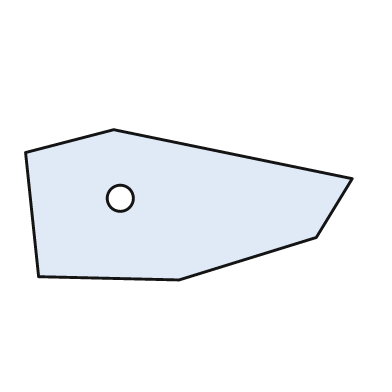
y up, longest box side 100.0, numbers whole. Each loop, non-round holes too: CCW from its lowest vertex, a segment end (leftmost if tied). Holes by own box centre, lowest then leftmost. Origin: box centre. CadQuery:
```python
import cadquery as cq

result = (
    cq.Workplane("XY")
    .moveTo(-3.0, -23.0)
    .lineTo(39.0, -10.0)
    .lineTo(50.0, 8.0)
    .lineTo(-23.0, 23.0)
    .lineTo(-50.0, 16.0)
    .lineTo(-46.0, -22.0)
    .close()
    .moveTo(-21.0, 2.0)
    .circle(4.0)
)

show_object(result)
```